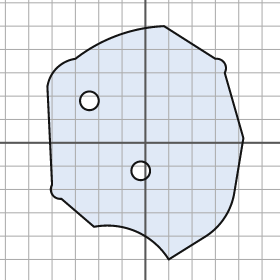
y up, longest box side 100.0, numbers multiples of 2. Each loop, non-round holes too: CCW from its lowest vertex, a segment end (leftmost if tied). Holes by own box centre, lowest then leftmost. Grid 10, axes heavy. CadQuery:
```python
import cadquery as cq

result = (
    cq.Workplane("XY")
    .moveTo(10.0, -50.0)
    .lineTo(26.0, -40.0)
    .threePointArc((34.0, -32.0), (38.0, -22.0))
    .lineTo(42.0, 2.0)
    .lineTo(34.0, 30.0)
    .threePointArc((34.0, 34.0), (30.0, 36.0))
    .lineTo(8.0, 50.0)
    .threePointArc((-12.0, 46.0), (-30.0, 36.0))
    .threePointArc((-38.0, 32.0), (-42.0, 24.0))
    .lineTo(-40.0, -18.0)
    .threePointArc((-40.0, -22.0), (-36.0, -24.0))
    .lineTo(-22.0, -36.0)
    .threePointArc((-4.0, -38.0), (10.0, -50.0))
    .close()
    .moveTo(-2.0, -12.0)
    .circle(4.0)
    .moveTo(-24.0, 18.0)
    .circle(4.0)
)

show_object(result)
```